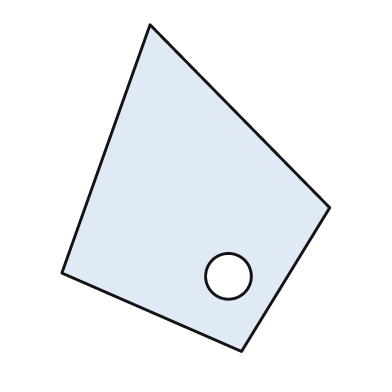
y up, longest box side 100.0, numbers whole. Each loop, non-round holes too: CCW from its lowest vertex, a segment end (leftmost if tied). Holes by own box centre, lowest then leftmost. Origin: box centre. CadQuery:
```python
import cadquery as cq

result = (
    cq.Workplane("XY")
    .moveTo(14.0, -50.0)
    .lineTo(41.0, -6.0)
    .lineTo(-14.0, 50.0)
    .lineTo(-41.0, -26.0)
    .close()
    .moveTo(10.0, -27.0)
    .circle(7.0)
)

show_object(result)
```